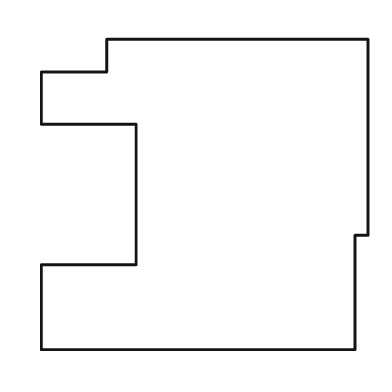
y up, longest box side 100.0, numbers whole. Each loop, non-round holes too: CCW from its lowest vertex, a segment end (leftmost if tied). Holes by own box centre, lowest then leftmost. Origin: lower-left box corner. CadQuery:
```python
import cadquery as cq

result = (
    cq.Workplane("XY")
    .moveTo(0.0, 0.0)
    .lineTo(96.0, 0.0)
    .lineTo(96.0, 35.0)
    .lineTo(100.0, 35.0)
    .lineTo(100.0, 95.0)
    .lineTo(20.0, 95.0)
    .lineTo(20.0, 85.0)
    .lineTo(0.0, 85.0)
    .lineTo(0.0, 69.0)
    .lineTo(29.0, 69.0)
    .lineTo(29.0, 26.0)
    .lineTo(0.0, 26.0)
    .close()
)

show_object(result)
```